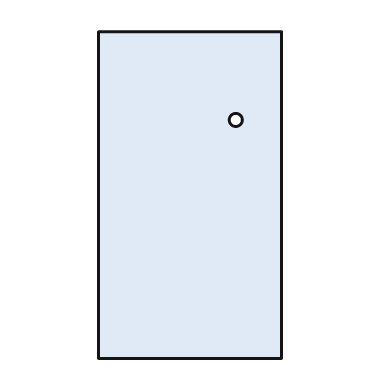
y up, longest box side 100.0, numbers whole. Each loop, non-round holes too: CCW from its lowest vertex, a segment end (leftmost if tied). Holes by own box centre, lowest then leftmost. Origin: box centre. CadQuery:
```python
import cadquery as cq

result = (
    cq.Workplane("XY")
    .moveTo(-28.0, -50.0)
    .lineTo(28.0, -50.0)
    .lineTo(28.0, 50.0)
    .lineTo(-28.0, 50.0)
    .close()
    .moveTo(14.0, 23.0)
    .circle(2.0)
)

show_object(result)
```